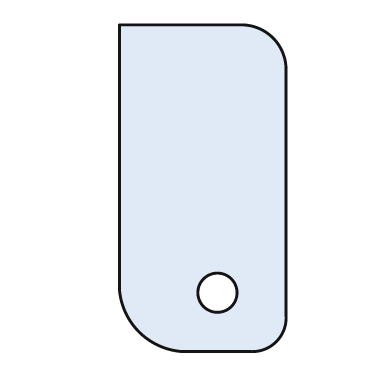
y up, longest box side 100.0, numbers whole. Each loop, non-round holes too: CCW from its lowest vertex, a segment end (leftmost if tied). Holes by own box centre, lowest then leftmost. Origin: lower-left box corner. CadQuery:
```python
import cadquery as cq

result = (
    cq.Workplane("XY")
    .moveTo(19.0, 0.0)
    .lineTo(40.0, 0.0)
    .threePointArc((48.0, 3.0), (51.0, 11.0))
    .lineTo(51.0, 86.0)
    .threePointArc((47.0, 96.0), (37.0, 100.0))
    .lineTo(0.0, 100.0)
    .lineTo(0.0, 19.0)
    .threePointArc((6.0, 6.0), (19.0, 0.0))
    .close()
    .moveTo(30.0, 18.0)
    .circle(6.0)
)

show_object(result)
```